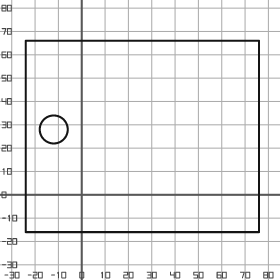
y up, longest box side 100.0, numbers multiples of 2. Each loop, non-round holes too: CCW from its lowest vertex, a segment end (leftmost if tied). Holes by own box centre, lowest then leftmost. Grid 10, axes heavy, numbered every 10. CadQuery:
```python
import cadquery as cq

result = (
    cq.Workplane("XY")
    .moveTo(-24.0, -16.0)
    .lineTo(76.0, -16.0)
    .lineTo(76.0, 66.0)
    .lineTo(-24.0, 66.0)
    .close()
    .moveTo(-12.0, 28.0)
    .circle(6.0)
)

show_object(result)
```